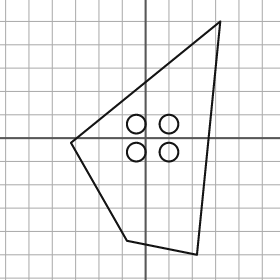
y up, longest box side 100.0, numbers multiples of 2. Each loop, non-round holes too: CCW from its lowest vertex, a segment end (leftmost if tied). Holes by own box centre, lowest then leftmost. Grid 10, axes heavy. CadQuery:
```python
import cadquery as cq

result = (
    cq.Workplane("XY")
    .moveTo(22.0, -50.0)
    .lineTo(32.0, 50.0)
    .lineTo(-32.0, -2.0)
    .lineTo(-8.0, -44.0)
    .close()
    .moveTo(-4.0, -6.0)
    .circle(4.0)
    .moveTo(10.0, -6.0)
    .circle(4.0)
    .moveTo(-4.0, 6.0)
    .circle(4.0)
    .moveTo(10.0, 6.0)
    .circle(4.0)
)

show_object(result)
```